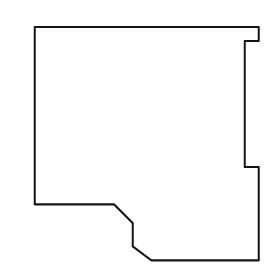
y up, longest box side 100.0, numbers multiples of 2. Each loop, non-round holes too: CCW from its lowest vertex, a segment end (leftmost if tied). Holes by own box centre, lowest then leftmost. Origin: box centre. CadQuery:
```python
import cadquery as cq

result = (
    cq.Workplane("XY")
    .moveTo(2.0, -50.0)
    .lineTo(48.0, -50.0)
    .lineTo(48.0, -10.0)
    .lineTo(42.0, -10.0)
    .lineTo(42.0, 44.0)
    .lineTo(48.0, 44.0)
    .lineTo(48.0, 50.0)
    .lineTo(-48.0, 50.0)
    .lineTo(-48.0, -26.0)
    .lineTo(-14.0, -26.0)
    .lineTo(-6.0, -34.0)
    .lineTo(-6.0, -44.0)
    .close()
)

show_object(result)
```